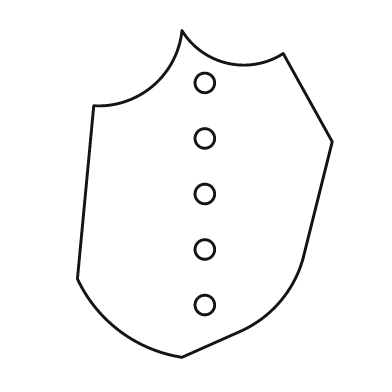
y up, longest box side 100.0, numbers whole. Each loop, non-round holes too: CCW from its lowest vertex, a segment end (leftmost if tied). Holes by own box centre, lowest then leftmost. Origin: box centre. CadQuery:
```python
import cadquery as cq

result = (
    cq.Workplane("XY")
    .moveTo(-7.0, -50.0)
    .lineTo(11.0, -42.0)
    .threePointArc((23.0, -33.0), (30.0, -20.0))
    .lineTo(39.0, 16.0)
    .lineTo(24.0, 43.0)
    .threePointArc((7.0, 40.0), (-7.0, 50.0))
    .threePointArc((-16.0, 33.0), (-34.0, 27.0))
    .lineTo(-39.0, -26.0)
    .threePointArc((-26.0, -42.0), (-7.0, -50.0))
    .close()
    .moveTo(0.0, -34.0)
    .circle(3.0)
    .moveTo(0.0, -17.0)
    .circle(3.0)
    .moveTo(0.0, 0.0)
    .circle(3.0)
    .moveTo(0.0, 17.0)
    .circle(3.0)
    .moveTo(0.0, 34.0)
    .circle(3.0)
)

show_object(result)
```